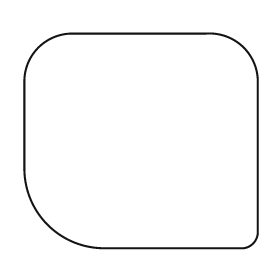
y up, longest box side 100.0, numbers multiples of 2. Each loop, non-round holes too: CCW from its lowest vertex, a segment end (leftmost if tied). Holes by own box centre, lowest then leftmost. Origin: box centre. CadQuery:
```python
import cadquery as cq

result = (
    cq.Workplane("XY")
    .moveTo(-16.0, -46.0)
    .lineTo(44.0, -46.0)
    .threePointArc((48.0, -44.0), (50.0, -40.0))
    .lineTo(50.0, 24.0)
    .threePointArc((44.0, 40.0), (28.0, 46.0))
    .lineTo(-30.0, 46.0)
    .threePointArc((-44.0, 40.0), (-50.0, 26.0))
    .lineTo(-50.0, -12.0)
    .threePointArc((-40.0, -36.0), (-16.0, -46.0))
    .close()
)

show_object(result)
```